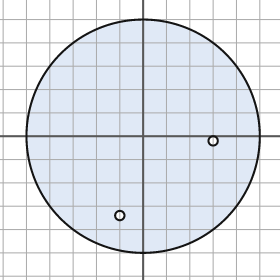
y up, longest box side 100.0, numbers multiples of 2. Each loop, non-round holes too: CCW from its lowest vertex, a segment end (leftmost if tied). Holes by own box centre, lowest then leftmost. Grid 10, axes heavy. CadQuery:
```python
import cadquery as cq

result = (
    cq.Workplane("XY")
    .moveTo(0.0, 0.0)
    .circle(50.0)
    .moveTo(-10.0, -34.0)
    .circle(2.0)
    .moveTo(30.0, -2.0)
    .circle(2.0)
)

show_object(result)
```